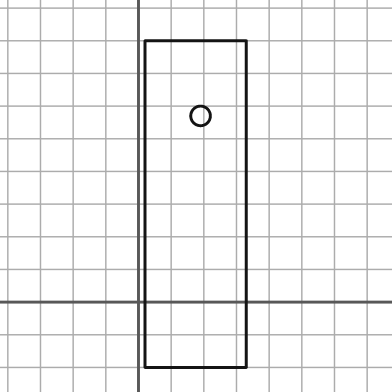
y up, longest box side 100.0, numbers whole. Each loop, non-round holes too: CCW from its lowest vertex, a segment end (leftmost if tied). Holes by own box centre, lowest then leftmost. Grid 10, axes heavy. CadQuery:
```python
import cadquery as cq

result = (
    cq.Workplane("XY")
    .moveTo(2.0, -20.0)
    .lineTo(33.0, -20.0)
    .lineTo(33.0, 80.0)
    .lineTo(2.0, 80.0)
    .close()
    .moveTo(19.0, 57.0)
    .circle(3.0)
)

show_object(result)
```